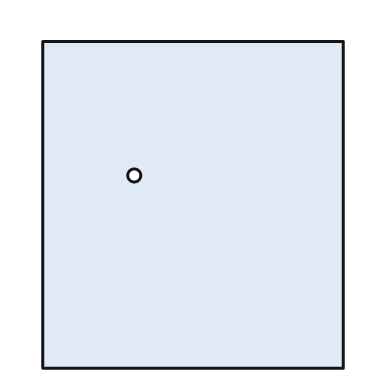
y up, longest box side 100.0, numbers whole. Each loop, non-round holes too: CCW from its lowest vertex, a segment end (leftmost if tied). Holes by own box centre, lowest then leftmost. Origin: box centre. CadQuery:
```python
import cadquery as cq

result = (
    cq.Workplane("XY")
    .moveTo(-46.0, -50.0)
    .lineTo(46.0, -50.0)
    .lineTo(46.0, 50.0)
    .lineTo(-46.0, 50.0)
    .close()
    .moveTo(-18.0, 9.0)
    .circle(2.0)
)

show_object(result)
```